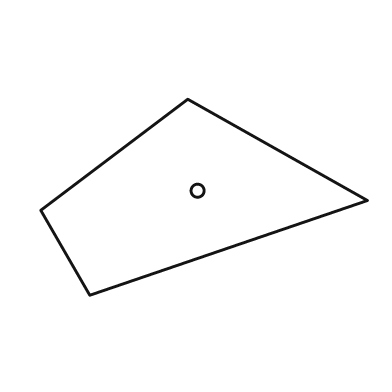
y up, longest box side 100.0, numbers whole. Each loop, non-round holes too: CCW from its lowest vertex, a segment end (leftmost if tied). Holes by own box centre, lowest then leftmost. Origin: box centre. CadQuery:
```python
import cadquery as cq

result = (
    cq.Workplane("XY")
    .moveTo(-35.0, -30.0)
    .lineTo(50.0, -1.0)
    .lineTo(-5.0, 30.0)
    .lineTo(-50.0, -4.0)
    .close()
    .moveTo(-2.0, 2.0)
    .circle(2.0)
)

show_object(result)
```